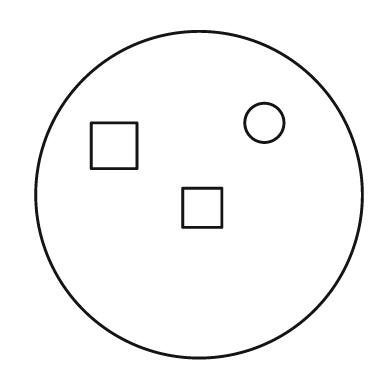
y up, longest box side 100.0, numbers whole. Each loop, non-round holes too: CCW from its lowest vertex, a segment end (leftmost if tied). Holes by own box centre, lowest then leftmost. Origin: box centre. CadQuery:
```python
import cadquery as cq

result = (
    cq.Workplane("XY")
    .moveTo(0.0, 0.0)
    .circle(50.0)
    .moveTo(-5.0, -10.0)
    .lineTo(7.0, -10.0)
    .lineTo(7.0, 2.0)
    .lineTo(-5.0, 2.0)
    .close()
    .moveTo(-33.0, 8.0)
    .lineTo(-19.0, 8.0)
    .lineTo(-19.0, 22.0)
    .lineTo(-33.0, 22.0)
    .close()
    .moveTo(20.0, 22.0)
    .circle(6.0)
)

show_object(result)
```